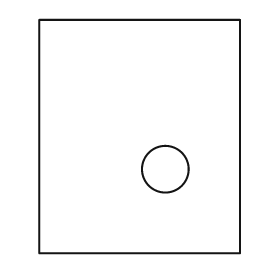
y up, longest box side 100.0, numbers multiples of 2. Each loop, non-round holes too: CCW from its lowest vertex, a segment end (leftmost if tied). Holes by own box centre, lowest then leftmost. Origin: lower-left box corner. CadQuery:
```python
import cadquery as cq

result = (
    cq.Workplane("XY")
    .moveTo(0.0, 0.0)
    .lineTo(86.0, 0.0)
    .lineTo(86.0, 100.0)
    .lineTo(0.0, 100.0)
    .close()
    .moveTo(54.0, 36.0)
    .circle(10.0)
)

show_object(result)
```